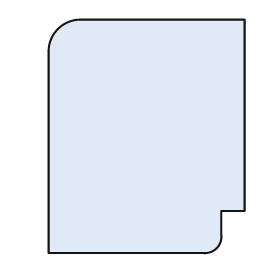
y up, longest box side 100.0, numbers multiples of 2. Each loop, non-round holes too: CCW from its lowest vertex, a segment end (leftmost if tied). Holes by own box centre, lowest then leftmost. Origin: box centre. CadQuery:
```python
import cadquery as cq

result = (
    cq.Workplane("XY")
    .moveTo(-42.0, -50.0)
    .lineTo(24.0, -50.0)
    .threePointArc((30.0, -48.0), (32.0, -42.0))
    .lineTo(32.0, -32.0)
    .lineTo(42.0, -32.0)
    .lineTo(42.0, 50.0)
    .lineTo(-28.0, 50.0)
    .threePointArc((-38.0, 46.0), (-42.0, 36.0))
    .close()
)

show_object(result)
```